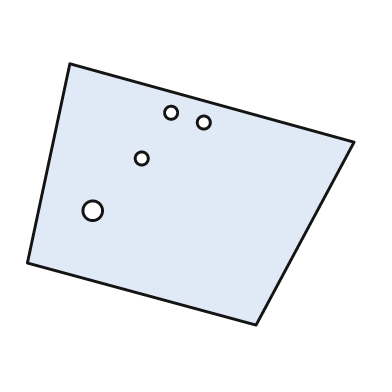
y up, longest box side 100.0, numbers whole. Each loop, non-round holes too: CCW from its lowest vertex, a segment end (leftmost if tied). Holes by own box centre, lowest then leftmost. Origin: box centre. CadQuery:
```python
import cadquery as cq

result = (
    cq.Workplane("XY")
    .moveTo(20.0, -40.0)
    .lineTo(50.0, 16.0)
    .lineTo(-37.0, 40.0)
    .lineTo(-50.0, -21.0)
    .close()
    .moveTo(-30.0, -5.0)
    .circle(3.0)
    .moveTo(-15.0, 11.0)
    .circle(2.0)
    .moveTo(4.0, 22.0)
    .circle(2.0)
    .moveTo(-6.0, 25.0)
    .circle(2.0)
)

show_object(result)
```